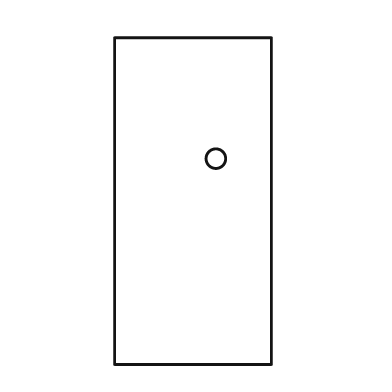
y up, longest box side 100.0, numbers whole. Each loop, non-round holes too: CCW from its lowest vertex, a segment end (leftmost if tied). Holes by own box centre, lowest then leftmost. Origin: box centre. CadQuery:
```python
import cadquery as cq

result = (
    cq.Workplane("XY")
    .moveTo(-24.0, -50.0)
    .lineTo(24.0, -50.0)
    .lineTo(24.0, 50.0)
    .lineTo(-24.0, 50.0)
    .close()
    .moveTo(7.0, 13.0)
    .circle(3.0)
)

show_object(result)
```